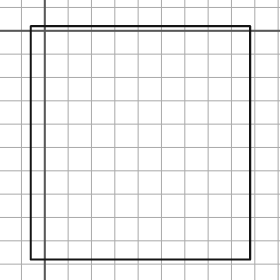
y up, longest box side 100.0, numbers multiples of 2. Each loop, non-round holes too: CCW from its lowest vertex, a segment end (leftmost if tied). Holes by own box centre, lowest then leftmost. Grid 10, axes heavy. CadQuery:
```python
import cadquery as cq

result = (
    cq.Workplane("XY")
    .moveTo(-6.0, -98.0)
    .lineTo(88.0, -98.0)
    .lineTo(88.0, 2.0)
    .lineTo(-6.0, 2.0)
    .close()
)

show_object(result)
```